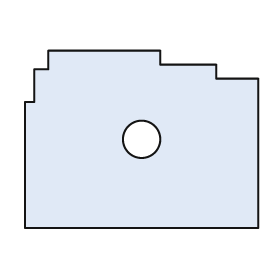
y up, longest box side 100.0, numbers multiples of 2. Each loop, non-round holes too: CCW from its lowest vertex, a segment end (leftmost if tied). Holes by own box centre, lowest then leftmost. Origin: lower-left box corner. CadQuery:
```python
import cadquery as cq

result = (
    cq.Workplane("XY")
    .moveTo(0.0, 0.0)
    .lineTo(100.0, 0.0)
    .lineTo(100.0, 64.0)
    .lineTo(82.0, 64.0)
    .lineTo(82.0, 70.0)
    .lineTo(58.0, 70.0)
    .lineTo(58.0, 76.0)
    .lineTo(10.0, 76.0)
    .lineTo(10.0, 68.0)
    .lineTo(4.0, 68.0)
    .lineTo(4.0, 54.0)
    .lineTo(0.0, 54.0)
    .close()
    .moveTo(50.0, 38.0)
    .circle(8.0)
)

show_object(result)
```